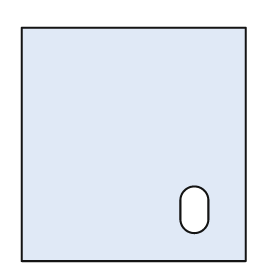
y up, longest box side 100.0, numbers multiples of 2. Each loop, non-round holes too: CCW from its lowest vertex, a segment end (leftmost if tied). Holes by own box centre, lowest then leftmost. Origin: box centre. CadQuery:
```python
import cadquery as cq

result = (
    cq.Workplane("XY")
    .moveTo(-48.0, -50.0)
    .lineTo(48.0, -50.0)
    .lineTo(48.0, 50.0)
    .lineTo(-48.0, 50.0)
    .close()
    .moveTo(20.0, -32.0)
    .threePointArc((26.0, -38.0), (32.0, -32.0))
    .lineTo(32.0, -24.0)
    .threePointArc((26.0, -18.0), (20.0, -24.0))
    .close()
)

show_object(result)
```